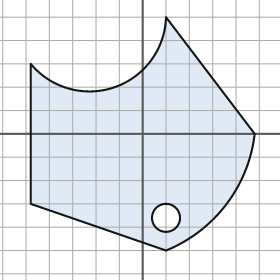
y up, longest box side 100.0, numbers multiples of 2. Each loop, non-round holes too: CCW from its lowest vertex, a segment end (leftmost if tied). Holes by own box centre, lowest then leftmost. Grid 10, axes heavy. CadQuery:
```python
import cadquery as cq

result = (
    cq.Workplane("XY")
    .moveTo(10.0, -50.0)
    .threePointArc((36.0, -30.0), (48.0, 0.0))
    .lineTo(10.0, 50.0)
    .threePointArc((-12.0, 20.0), (-48.0, 30.0))
    .lineTo(-48.0, -30.0)
    .close()
    .moveTo(10.0, -36.0)
    .circle(6.0)
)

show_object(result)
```